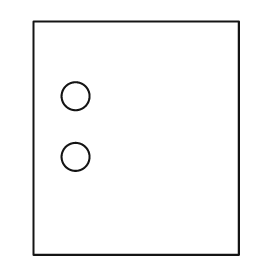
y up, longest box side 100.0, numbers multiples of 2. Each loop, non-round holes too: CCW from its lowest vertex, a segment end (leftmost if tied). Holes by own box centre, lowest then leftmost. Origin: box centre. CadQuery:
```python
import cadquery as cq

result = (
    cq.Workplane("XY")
    .moveTo(-44.0, -50.0)
    .lineTo(44.0, -50.0)
    .lineTo(44.0, 50.0)
    .lineTo(-44.0, 50.0)
    .close()
    .moveTo(-26.0, -8.0)
    .circle(6.0)
    .moveTo(-26.0, 18.0)
    .circle(6.0)
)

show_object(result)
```